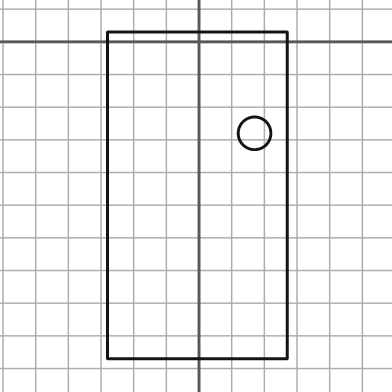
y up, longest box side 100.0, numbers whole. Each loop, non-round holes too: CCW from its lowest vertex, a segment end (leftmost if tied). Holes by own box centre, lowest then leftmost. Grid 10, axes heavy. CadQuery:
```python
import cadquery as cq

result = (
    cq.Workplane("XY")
    .moveTo(-28.0, -97.0)
    .lineTo(27.0, -97.0)
    .lineTo(27.0, 3.0)
    .lineTo(-28.0, 3.0)
    .close()
    .moveTo(17.0, -28.0)
    .circle(5.0)
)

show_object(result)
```